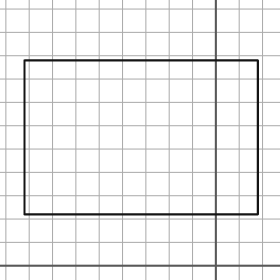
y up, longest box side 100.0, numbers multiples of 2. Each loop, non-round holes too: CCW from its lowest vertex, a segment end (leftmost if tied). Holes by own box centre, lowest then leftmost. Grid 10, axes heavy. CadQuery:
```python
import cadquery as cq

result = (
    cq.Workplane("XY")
    .moveTo(-82.0, 22.0)
    .lineTo(18.0, 22.0)
    .lineTo(18.0, 88.0)
    .lineTo(-82.0, 88.0)
    .close()
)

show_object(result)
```